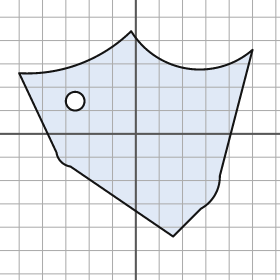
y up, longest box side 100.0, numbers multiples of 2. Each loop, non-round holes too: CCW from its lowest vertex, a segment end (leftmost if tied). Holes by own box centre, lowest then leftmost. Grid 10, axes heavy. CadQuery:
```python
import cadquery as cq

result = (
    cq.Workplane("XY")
    .moveTo(16.0, -44.0)
    .lineTo(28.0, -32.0)
    .threePointArc((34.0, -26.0), (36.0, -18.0))
    .lineTo(50.0, 36.0)
    .threePointArc((22.0, 28.0), (-2.0, 44.0))
    .threePointArc((-24.0, 30.0), (-50.0, 26.0))
    .lineTo(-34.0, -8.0)
    .threePointArc((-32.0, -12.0), (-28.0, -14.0))
    .close()
    .moveTo(-26.0, 14.0)
    .circle(4.0)
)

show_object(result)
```